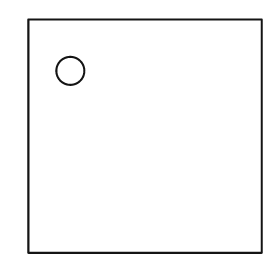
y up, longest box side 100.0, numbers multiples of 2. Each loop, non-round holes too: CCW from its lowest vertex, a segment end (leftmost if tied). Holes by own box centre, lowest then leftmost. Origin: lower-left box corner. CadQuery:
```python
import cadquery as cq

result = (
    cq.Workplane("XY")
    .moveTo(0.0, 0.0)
    .lineTo(100.0, 0.0)
    .lineTo(100.0, 100.0)
    .lineTo(0.0, 100.0)
    .close()
    .moveTo(18.0, 78.0)
    .circle(6.0)
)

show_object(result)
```